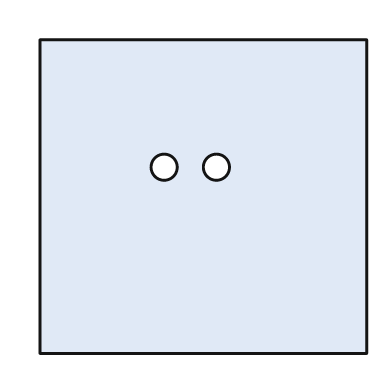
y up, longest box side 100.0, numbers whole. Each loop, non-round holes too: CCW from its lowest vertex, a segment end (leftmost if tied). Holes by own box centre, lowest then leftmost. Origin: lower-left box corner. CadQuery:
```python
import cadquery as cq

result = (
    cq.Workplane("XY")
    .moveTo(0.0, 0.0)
    .lineTo(100.0, 0.0)
    .lineTo(100.0, 96.0)
    .lineTo(0.0, 96.0)
    .close()
    .moveTo(38.0, 57.0)
    .circle(4.0)
    .moveTo(54.0, 57.0)
    .circle(4.0)
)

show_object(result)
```